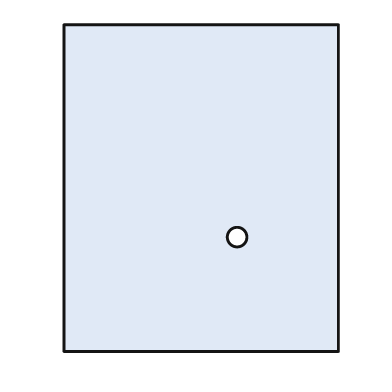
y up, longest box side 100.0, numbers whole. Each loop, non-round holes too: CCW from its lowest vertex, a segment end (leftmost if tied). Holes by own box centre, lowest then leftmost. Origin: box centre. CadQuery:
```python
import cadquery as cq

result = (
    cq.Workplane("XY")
    .moveTo(-42.0, -50.0)
    .lineTo(42.0, -50.0)
    .lineTo(42.0, 50.0)
    .lineTo(-42.0, 50.0)
    .close()
    .moveTo(11.0, -15.0)
    .circle(3.0)
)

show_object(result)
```